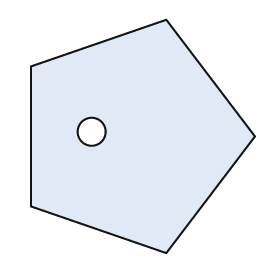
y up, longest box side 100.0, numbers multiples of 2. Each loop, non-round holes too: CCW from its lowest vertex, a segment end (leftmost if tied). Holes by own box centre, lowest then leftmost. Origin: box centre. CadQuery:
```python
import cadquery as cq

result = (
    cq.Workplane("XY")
    .moveTo(10.0, -50.0)
    .lineTo(48.0, 0.0)
    .lineTo(10.0, 50.0)
    .lineTo(-48.0, 30.0)
    .lineTo(-48.0, -30.0)
    .close()
    .moveTo(-22.0, 2.0)
    .circle(6.0)
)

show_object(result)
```